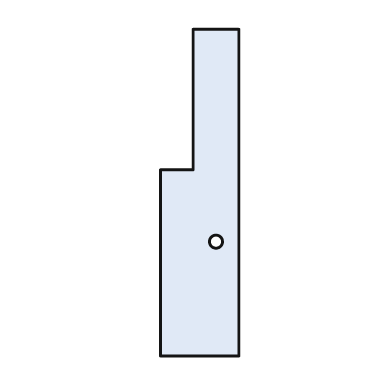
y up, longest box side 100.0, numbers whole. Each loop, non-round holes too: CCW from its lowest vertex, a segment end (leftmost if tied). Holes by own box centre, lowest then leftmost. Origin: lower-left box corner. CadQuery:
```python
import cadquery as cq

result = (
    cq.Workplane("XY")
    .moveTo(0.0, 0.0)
    .lineTo(24.0, 0.0)
    .lineTo(24.0, 100.0)
    .lineTo(10.0, 100.0)
    .lineTo(10.0, 57.0)
    .lineTo(0.0, 57.0)
    .close()
    .moveTo(17.0, 35.0)
    .circle(2.0)
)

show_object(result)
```